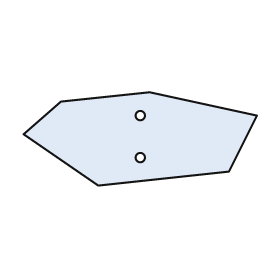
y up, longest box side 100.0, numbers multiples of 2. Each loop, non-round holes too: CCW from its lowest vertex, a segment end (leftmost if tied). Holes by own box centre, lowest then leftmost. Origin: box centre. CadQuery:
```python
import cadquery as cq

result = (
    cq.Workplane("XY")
    .moveTo(-18.0, -20.0)
    .lineTo(38.0, -14.0)
    .lineTo(50.0, 10.0)
    .lineTo(4.0, 20.0)
    .lineTo(-34.0, 16.0)
    .lineTo(-50.0, 2.0)
    .close()
    .moveTo(0.0, -8.0)
    .circle(2.0)
    .moveTo(0.0, 10.0)
    .circle(2.0)
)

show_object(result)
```